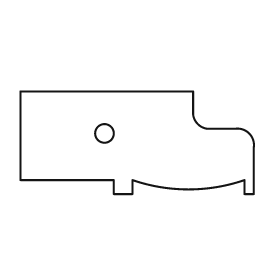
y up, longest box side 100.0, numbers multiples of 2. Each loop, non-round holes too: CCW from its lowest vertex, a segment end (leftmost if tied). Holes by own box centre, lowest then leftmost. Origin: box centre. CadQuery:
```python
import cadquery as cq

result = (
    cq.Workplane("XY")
    .moveTo(-10.0, -22.0)
    .lineTo(-2.0, -22.0)
    .lineTo(-2.0, -16.0)
    .threePointArc((22.0, -20.0), (46.0, -16.0))
    .lineTo(46.0, -22.0)
    .lineTo(50.0, -22.0)
    .lineTo(50.0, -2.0)
    .threePointArc((48.0, 4.0), (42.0, 6.0))
    .lineTo(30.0, 6.0)
    .threePointArc((26.0, 8.0), (24.0, 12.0))
    .lineTo(24.0, 22.0)
    .lineTo(-50.0, 22.0)
    .lineTo(-50.0, -16.0)
    .lineTo(-10.0, -16.0)
    .close()
    .moveTo(-14.0, 4.0)
    .circle(4.0)
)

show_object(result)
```